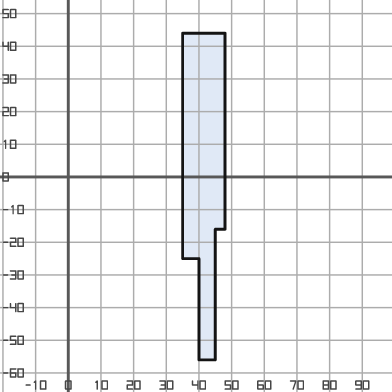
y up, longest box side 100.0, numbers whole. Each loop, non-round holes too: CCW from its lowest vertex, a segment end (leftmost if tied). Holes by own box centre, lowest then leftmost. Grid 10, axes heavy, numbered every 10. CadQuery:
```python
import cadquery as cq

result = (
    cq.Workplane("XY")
    .moveTo(40.0, -56.0)
    .lineTo(45.0, -56.0)
    .lineTo(45.0, -16.0)
    .lineTo(48.0, -16.0)
    .lineTo(48.0, 44.0)
    .lineTo(35.0, 44.0)
    .lineTo(35.0, -25.0)
    .lineTo(40.0, -25.0)
    .close()
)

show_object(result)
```